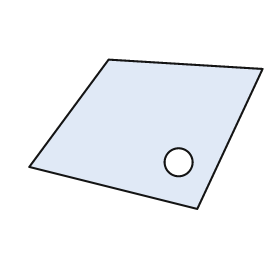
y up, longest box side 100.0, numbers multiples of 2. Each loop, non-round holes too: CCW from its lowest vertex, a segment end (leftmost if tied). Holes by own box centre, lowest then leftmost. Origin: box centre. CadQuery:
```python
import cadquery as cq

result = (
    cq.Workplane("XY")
    .moveTo(22.0, -32.0)
    .lineTo(50.0, 28.0)
    .lineTo(-16.0, 32.0)
    .lineTo(-50.0, -14.0)
    .close()
    .moveTo(14.0, -12.0)
    .circle(6.0)
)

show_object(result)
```